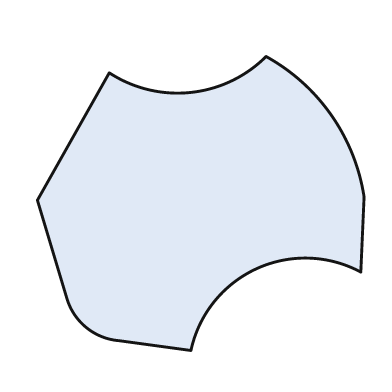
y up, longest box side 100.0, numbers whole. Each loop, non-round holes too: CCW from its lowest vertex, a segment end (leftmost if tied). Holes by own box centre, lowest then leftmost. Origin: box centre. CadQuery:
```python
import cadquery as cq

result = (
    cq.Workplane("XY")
    .moveTo(-3.0, -45.0)
    .threePointArc((17.0, -20.0), (49.0, -21.0))
    .lineTo(50.0, 2.0)
    .threePointArc((40.0, 27.0), (20.0, 45.0))
    .threePointArc((-3.0, 34.0), (-28.0, 40.0))
    .lineTo(-50.0, 1.0)
    .lineTo(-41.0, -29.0)
    .threePointArc((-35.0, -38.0), (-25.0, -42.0))
    .close()
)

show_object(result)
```